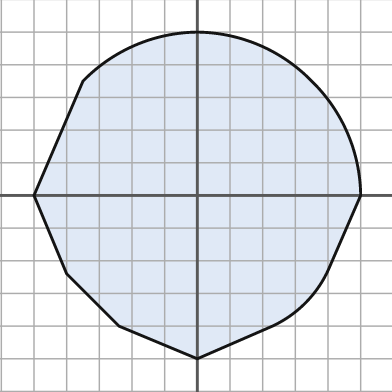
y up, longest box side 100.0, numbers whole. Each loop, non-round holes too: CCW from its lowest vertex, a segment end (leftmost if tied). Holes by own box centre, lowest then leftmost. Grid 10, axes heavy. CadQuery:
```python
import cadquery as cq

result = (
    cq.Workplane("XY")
    .moveTo(0.0, -50.0)
    .lineTo(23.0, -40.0)
    .threePointArc((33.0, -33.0), (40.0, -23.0))
    .lineTo(50.0, 0.0)
    .threePointArc((46.0, 19.0), (35.0, 35.0))
    .threePointArc((19.0, 46.0), (0.0, 50.0))
    .threePointArc((-19.0, 46.0), (-35.0, 35.0))
    .lineTo(-50.0, 0.0)
    .lineTo(-40.0, -24.0)
    .lineTo(-24.0, -40.0)
    .close()
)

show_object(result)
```